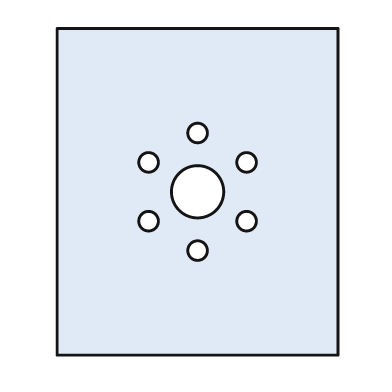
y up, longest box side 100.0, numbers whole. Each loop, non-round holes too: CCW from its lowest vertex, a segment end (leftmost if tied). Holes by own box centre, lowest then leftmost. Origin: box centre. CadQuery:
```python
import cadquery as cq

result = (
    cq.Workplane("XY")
    .moveTo(-43.0, -50.0)
    .lineTo(43.0, -50.0)
    .lineTo(43.0, 50.0)
    .lineTo(-43.0, 50.0)
    .close()
    .moveTo(0.0, -18.0)
    .circle(3.0)
    .moveTo(-15.0, -9.0)
    .circle(3.0)
    .moveTo(15.0, -9.0)
    .circle(3.0)
    .moveTo(0.0, 0.0)
    .circle(8.0)
    .moveTo(-15.0, 9.0)
    .circle(3.0)
    .moveTo(15.0, 9.0)
    .circle(3.0)
    .moveTo(0.0, 18.0)
    .circle(3.0)
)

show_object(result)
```